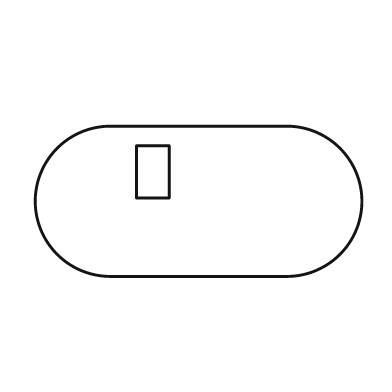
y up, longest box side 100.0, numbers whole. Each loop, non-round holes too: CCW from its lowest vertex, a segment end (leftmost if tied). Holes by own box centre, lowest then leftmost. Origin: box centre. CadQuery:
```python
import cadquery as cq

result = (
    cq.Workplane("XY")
    .moveTo(-27.0, -23.0)
    .lineTo(27.0, -23.0)
    .threePointArc((50.0, 0.0), (27.0, 23.0))
    .lineTo(-27.0, 23.0)
    .threePointArc((-50.0, 0.0), (-27.0, -23.0))
    .close()
    .moveTo(-19.0, 1.0)
    .lineTo(-9.0, 1.0)
    .lineTo(-9.0, 17.0)
    .lineTo(-19.0, 17.0)
    .close()
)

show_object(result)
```